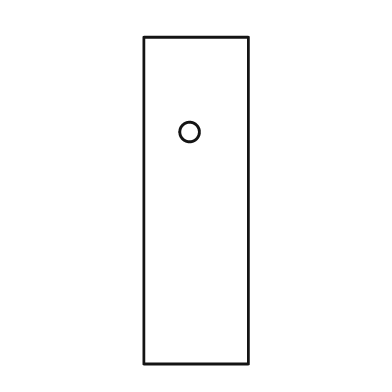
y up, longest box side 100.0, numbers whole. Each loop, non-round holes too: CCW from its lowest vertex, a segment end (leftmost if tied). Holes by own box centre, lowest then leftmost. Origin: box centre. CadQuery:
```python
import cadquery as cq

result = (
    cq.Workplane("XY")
    .moveTo(-16.0, -50.0)
    .lineTo(16.0, -50.0)
    .lineTo(16.0, 50.0)
    .lineTo(-16.0, 50.0)
    .close()
    .moveTo(-2.0, 21.0)
    .circle(3.0)
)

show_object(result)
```